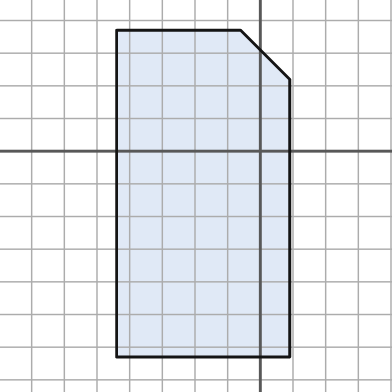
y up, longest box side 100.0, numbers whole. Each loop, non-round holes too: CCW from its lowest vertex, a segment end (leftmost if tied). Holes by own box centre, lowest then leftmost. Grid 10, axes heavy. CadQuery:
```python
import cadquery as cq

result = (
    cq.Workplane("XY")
    .moveTo(-44.0, -63.0)
    .lineTo(9.0, -63.0)
    .lineTo(9.0, 22.0)
    .lineTo(-6.0, 37.0)
    .lineTo(-44.0, 37.0)
    .close()
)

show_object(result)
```